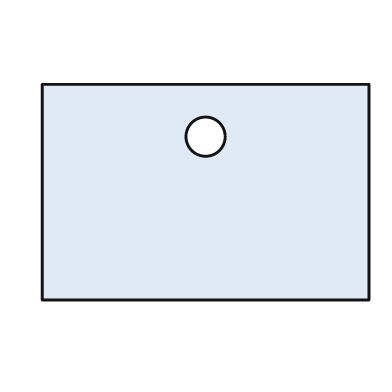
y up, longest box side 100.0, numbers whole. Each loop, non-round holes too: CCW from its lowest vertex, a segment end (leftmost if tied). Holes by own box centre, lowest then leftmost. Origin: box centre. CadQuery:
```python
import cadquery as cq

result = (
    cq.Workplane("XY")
    .moveTo(-50.0, -33.0)
    .lineTo(50.0, -33.0)
    .lineTo(50.0, 33.0)
    .lineTo(-50.0, 33.0)
    .close()
    .moveTo(0.0, 17.0)
    .circle(6.0)
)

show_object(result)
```